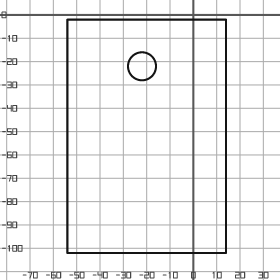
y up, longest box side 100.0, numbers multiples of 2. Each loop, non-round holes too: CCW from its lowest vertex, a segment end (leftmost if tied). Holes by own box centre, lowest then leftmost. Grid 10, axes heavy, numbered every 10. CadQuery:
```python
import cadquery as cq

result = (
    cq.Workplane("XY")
    .moveTo(-54.0, -102.0)
    .lineTo(14.0, -102.0)
    .lineTo(14.0, -2.0)
    .lineTo(-54.0, -2.0)
    .close()
    .moveTo(-22.0, -22.0)
    .circle(6.0)
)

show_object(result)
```